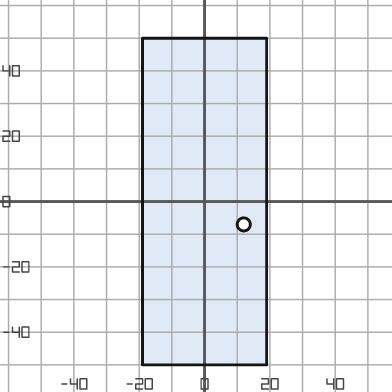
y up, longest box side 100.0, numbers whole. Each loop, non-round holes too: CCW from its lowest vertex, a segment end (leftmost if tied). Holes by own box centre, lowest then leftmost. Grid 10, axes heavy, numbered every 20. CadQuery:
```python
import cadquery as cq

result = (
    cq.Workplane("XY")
    .moveTo(-19.0, -50.0)
    .lineTo(19.0, -50.0)
    .lineTo(19.0, 50.0)
    .lineTo(-19.0, 50.0)
    .close()
    .moveTo(12.0, -7.0)
    .circle(2.0)
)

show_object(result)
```